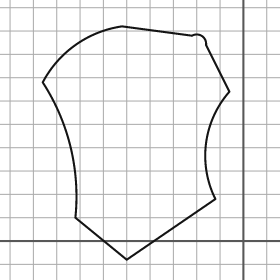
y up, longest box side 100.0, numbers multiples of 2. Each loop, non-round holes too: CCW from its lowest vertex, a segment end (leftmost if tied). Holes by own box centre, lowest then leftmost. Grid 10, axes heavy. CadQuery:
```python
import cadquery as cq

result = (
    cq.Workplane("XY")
    .moveTo(-50.0, -8.0)
    .lineTo(-12.0, 18.0)
    .threePointArc((-16.0, 42.0), (-6.0, 64.0))
    .lineTo(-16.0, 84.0)
    .threePointArc((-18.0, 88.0), (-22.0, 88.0))
    .lineTo(-52.0, 92.0)
    .threePointArc((-72.0, 84.0), (-86.0, 68.0))
    .threePointArc((-74.0, 40.0), (-72.0, 10.0))
    .close()
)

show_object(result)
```